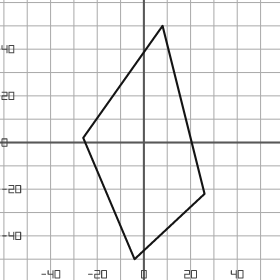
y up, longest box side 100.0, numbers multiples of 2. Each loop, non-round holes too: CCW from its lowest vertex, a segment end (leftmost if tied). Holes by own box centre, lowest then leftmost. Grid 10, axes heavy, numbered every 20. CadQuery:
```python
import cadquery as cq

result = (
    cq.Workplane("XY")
    .moveTo(-4.0, -50.0)
    .lineTo(26.0, -22.0)
    .lineTo(8.0, 50.0)
    .lineTo(-26.0, 2.0)
    .close()
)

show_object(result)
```